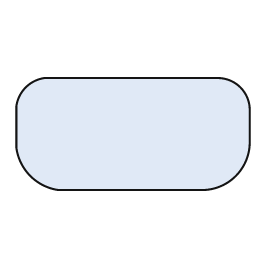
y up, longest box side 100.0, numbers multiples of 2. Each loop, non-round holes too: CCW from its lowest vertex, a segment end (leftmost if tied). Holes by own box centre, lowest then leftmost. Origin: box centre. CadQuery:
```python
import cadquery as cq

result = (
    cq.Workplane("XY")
    .moveTo(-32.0, -24.0)
    .lineTo(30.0, -24.0)
    .threePointArc((44.0, -18.0), (50.0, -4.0))
    .lineTo(50.0, 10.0)
    .threePointArc((46.0, 20.0), (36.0, 24.0))
    .lineTo(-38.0, 24.0)
    .threePointArc((-46.0, 20.0), (-50.0, 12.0))
    .lineTo(-50.0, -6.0)
    .threePointArc((-44.0, -18.0), (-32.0, -24.0))
    .close()
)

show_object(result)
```